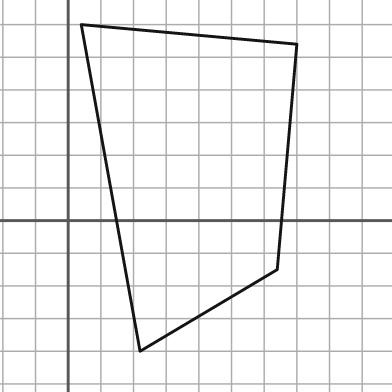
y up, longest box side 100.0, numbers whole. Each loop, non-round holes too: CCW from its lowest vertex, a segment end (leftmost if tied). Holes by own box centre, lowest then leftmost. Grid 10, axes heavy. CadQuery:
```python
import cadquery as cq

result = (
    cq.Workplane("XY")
    .moveTo(22.0, -40.0)
    .lineTo(64.0, -15.0)
    .lineTo(70.0, 54.0)
    .lineTo(4.0, 60.0)
    .close()
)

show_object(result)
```